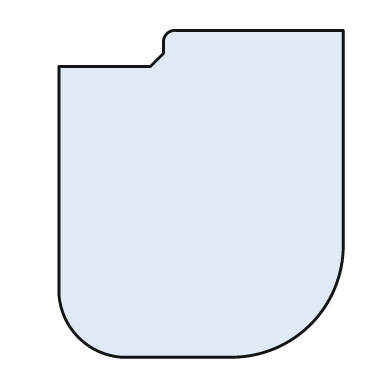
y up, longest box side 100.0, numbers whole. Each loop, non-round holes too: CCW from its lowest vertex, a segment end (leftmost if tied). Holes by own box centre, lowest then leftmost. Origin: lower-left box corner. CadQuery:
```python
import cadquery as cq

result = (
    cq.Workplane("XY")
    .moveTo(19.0, 0.0)
    .lineTo(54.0, 0.0)
    .threePointArc((77.0, 10.0), (87.0, 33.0))
    .lineTo(87.0, 100.0)
    .lineTo(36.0, 100.0)
    .threePointArc((33.0, 99.0), (32.0, 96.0))
    .lineTo(32.0, 93.0)
    .lineTo(28.0, 89.0)
    .lineTo(0.0, 89.0)
    .lineTo(0.0, 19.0)
    .threePointArc((6.0, 6.0), (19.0, 0.0))
    .close()
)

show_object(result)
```